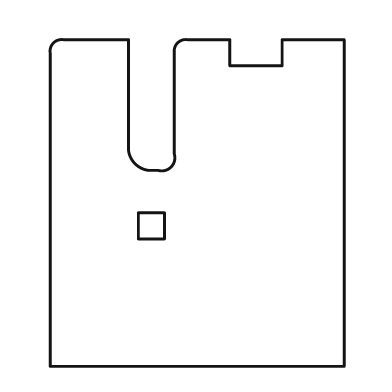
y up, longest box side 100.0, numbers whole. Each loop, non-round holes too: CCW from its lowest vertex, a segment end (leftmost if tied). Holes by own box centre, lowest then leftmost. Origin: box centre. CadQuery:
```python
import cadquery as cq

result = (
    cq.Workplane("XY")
    .moveTo(-45.0, -50.0)
    .lineTo(45.0, -50.0)
    .lineTo(45.0, 50.0)
    .lineTo(26.0, 50.0)
    .lineTo(26.0, 42.0)
    .lineTo(10.0, 42.0)
    .lineTo(10.0, 50.0)
    .lineTo(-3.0, 50.0)
    .threePointArc((-6.0, 49.0), (-7.0, 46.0))
    .lineTo(-7.0, 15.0)
    .threePointArc((-8.0, 11.0), (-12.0, 10.0))
    .lineTo(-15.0, 10.0)
    .threePointArc((-19.0, 12.0), (-21.0, 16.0))
    .lineTo(-21.0, 50.0)
    .lineTo(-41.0, 50.0)
    .threePointArc((-44.0, 49.0), (-45.0, 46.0))
    .close()
    .moveTo(-18.0, -11.0)
    .lineTo(-10.0, -11.0)
    .lineTo(-10.0, -3.0)
    .lineTo(-18.0, -3.0)
    .close()
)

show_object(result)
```